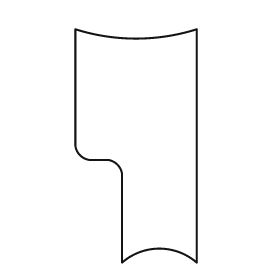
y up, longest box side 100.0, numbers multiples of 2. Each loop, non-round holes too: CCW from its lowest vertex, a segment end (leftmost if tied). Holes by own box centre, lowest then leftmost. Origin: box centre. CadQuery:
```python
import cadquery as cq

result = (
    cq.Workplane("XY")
    .moveTo(-6.0, -50.0)
    .threePointArc((10.0, -44.0), (26.0, -50.0))
    .lineTo(26.0, 50.0)
    .threePointArc((0.0, 46.0), (-26.0, 50.0))
    .lineTo(-26.0, 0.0)
    .threePointArc((-24.0, -4.0), (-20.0, -6.0))
    .lineTo(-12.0, -6.0)
    .threePointArc((-8.0, -8.0), (-6.0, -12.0))
    .close()
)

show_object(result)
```